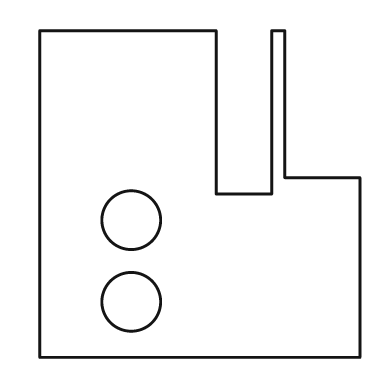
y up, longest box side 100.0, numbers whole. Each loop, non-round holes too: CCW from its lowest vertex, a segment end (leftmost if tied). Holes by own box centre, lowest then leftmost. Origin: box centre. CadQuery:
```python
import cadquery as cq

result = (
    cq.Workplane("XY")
    .moveTo(-49.0, -50.0)
    .lineTo(49.0, -50.0)
    .lineTo(49.0, 5.0)
    .lineTo(26.0, 5.0)
    .lineTo(26.0, 50.0)
    .lineTo(22.0, 50.0)
    .lineTo(22.0, 0.0)
    .lineTo(5.0, 0.0)
    .lineTo(5.0, 50.0)
    .lineTo(-49.0, 50.0)
    .close()
    .moveTo(-21.0, -33.0)
    .circle(9.0)
    .moveTo(-21.0, -8.0)
    .circle(9.0)
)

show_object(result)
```